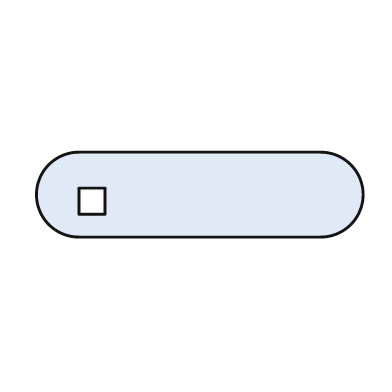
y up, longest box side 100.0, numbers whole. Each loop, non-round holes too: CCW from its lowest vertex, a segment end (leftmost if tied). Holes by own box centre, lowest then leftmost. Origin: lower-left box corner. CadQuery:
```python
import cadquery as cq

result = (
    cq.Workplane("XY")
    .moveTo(13.0, 0.0)
    .lineTo(87.0, 0.0)
    .threePointArc((100.0, 13.0), (87.0, 26.0))
    .lineTo(13.0, 26.0)
    .threePointArc((0.0, 13.0), (13.0, 0.0))
    .close()
    .moveTo(13.0, 7.0)
    .lineTo(21.0, 7.0)
    .lineTo(21.0, 15.0)
    .lineTo(13.0, 15.0)
    .close()
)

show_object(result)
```